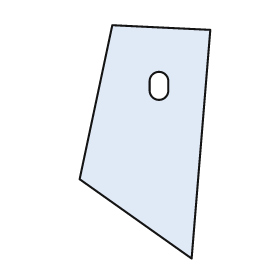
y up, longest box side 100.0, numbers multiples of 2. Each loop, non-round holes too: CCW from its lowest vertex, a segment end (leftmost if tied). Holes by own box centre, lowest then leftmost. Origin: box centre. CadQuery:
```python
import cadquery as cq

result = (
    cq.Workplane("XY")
    .moveTo(20.0, -50.0)
    .lineTo(28.0, 48.0)
    .lineTo(-14.0, 50.0)
    .lineTo(-28.0, -16.0)
    .close()
    .moveTo(2.0, 22.0)
    .threePointArc((6.0, 18.0), (10.0, 22.0))
    .lineTo(10.0, 26.0)
    .threePointArc((6.0, 30.0), (2.0, 26.0))
    .close()
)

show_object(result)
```